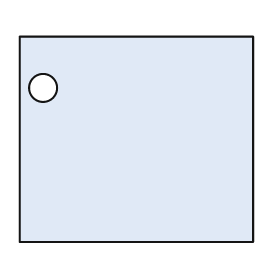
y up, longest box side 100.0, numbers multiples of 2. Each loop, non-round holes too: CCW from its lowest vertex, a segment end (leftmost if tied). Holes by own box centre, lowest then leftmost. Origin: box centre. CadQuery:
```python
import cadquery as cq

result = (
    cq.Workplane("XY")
    .moveTo(-50.0, -44.0)
    .lineTo(50.0, -44.0)
    .lineTo(50.0, 44.0)
    .lineTo(-50.0, 44.0)
    .close()
    .moveTo(-40.0, 22.0)
    .circle(6.0)
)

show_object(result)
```